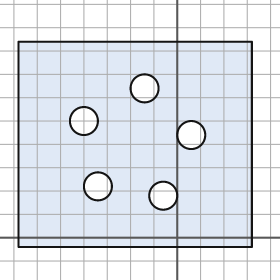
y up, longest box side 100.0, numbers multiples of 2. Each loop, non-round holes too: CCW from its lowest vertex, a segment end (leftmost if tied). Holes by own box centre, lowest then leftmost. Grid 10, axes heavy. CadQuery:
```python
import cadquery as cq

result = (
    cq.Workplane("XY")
    .moveTo(-68.0, -4.0)
    .lineTo(32.0, -4.0)
    .lineTo(32.0, 84.0)
    .lineTo(-68.0, 84.0)
    .close()
    .moveTo(-6.0, 18.0)
    .circle(6.0)
    .moveTo(-34.0, 22.0)
    .circle(6.0)
    .moveTo(6.0, 44.0)
    .circle(6.0)
    .moveTo(-40.0, 50.0)
    .circle(6.0)
    .moveTo(-14.0, 64.0)
    .circle(6.0)
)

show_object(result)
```